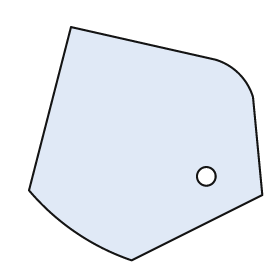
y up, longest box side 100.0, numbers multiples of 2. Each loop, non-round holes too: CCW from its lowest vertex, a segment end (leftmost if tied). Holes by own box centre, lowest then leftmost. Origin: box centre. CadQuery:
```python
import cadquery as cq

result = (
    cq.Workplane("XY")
    .moveTo(-6.0, -50.0)
    .lineTo(50.0, -22.0)
    .lineTo(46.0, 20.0)
    .threePointArc((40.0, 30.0), (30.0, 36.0))
    .lineTo(-32.0, 50.0)
    .lineTo(-50.0, -20.0)
    .threePointArc((-30.0, -38.0), (-6.0, -50.0))
    .close()
    .moveTo(26.0, -14.0)
    .circle(4.0)
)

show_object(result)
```